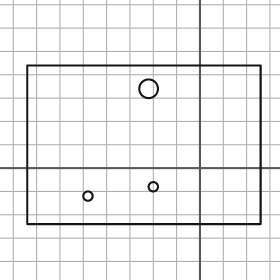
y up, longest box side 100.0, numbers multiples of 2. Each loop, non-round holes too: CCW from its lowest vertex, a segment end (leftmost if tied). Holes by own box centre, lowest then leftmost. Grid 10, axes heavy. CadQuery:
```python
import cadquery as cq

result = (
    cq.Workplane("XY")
    .moveTo(-74.0, -24.0)
    .lineTo(26.0, -24.0)
    .lineTo(26.0, 44.0)
    .lineTo(-74.0, 44.0)
    .close()
    .moveTo(-48.0, -12.0)
    .circle(2.0)
    .moveTo(-20.0, -8.0)
    .circle(2.0)
    .moveTo(-22.0, 34.0)
    .circle(4.0)
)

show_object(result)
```